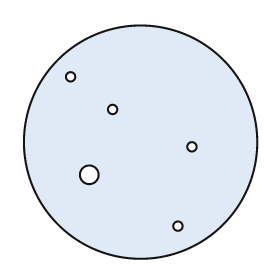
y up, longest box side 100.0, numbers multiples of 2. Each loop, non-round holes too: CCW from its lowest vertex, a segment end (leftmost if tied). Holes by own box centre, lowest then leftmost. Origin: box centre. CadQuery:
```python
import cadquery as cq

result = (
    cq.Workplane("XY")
    .moveTo(0.0, 0.0)
    .circle(50.0)
    .moveTo(16.0, -36.0)
    .circle(2.0)
    .moveTo(-22.0, -14.0)
    .circle(4.0)
    .moveTo(22.0, -2.0)
    .circle(2.0)
    .moveTo(-12.0, 14.0)
    .circle(2.0)
    .moveTo(-30.0, 28.0)
    .circle(2.0)
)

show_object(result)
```